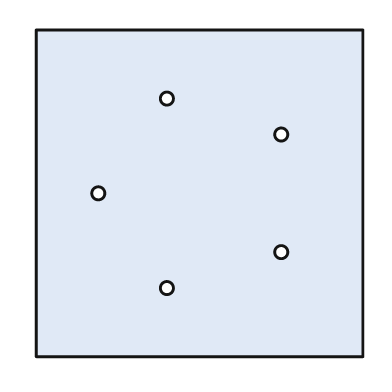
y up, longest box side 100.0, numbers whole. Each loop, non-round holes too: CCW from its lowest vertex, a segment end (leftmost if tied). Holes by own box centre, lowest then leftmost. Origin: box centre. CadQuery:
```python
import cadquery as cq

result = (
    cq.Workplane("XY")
    .moveTo(-50.0, -50.0)
    .lineTo(50.0, -50.0)
    .lineTo(50.0, 50.0)
    .lineTo(-50.0, 50.0)
    .close()
    .moveTo(-10.0, -29.0)
    .circle(2.0)
    .moveTo(25.0, -18.0)
    .circle(2.0)
    .moveTo(-31.0, 0.0)
    .circle(2.0)
    .moveTo(25.0, 18.0)
    .circle(2.0)
    .moveTo(-10.0, 29.0)
    .circle(2.0)
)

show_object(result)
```